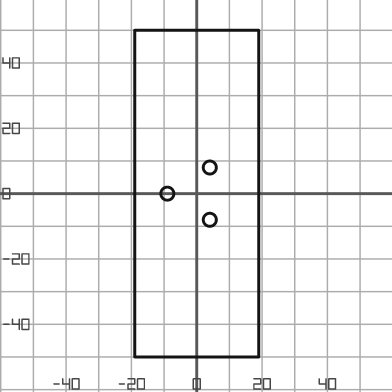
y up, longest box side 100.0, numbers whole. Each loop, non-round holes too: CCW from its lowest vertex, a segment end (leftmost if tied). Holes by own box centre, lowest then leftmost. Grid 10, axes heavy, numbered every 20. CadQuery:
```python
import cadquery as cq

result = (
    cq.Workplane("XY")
    .moveTo(-19.0, -50.0)
    .lineTo(19.0, -50.0)
    .lineTo(19.0, 50.0)
    .lineTo(-19.0, 50.0)
    .close()
    .moveTo(4.0, -8.0)
    .circle(2.0)
    .moveTo(-9.0, 0.0)
    .circle(2.0)
    .moveTo(4.0, 8.0)
    .circle(2.0)
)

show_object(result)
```